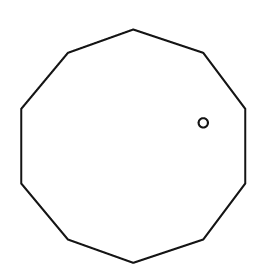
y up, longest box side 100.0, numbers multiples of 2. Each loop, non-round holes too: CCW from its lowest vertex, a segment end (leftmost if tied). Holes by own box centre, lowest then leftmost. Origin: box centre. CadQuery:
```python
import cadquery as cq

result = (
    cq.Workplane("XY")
    .moveTo(0.0, -50.0)
    .lineTo(30.0, -40.0)
    .lineTo(48.0, -16.0)
    .lineTo(48.0, 16.0)
    .lineTo(30.0, 40.0)
    .lineTo(0.0, 50.0)
    .lineTo(-28.0, 40.0)
    .lineTo(-48.0, 16.0)
    .lineTo(-48.0, -16.0)
    .lineTo(-28.0, -40.0)
    .close()
    .moveTo(30.0, 10.0)
    .circle(2.0)
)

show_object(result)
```